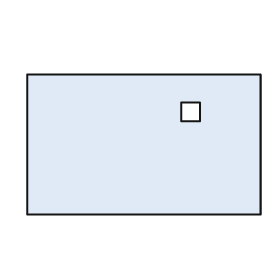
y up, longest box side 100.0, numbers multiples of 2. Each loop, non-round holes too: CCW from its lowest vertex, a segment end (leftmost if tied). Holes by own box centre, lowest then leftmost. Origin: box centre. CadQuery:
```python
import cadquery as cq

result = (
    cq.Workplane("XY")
    .moveTo(-50.0, -30.0)
    .lineTo(50.0, -30.0)
    .lineTo(50.0, 30.0)
    .lineTo(-50.0, 30.0)
    .close()
    .moveTo(16.0, 10.0)
    .lineTo(24.0, 10.0)
    .lineTo(24.0, 18.0)
    .lineTo(16.0, 18.0)
    .close()
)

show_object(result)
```